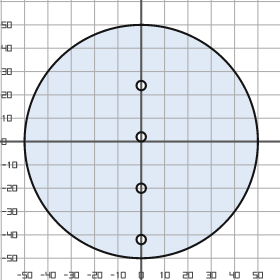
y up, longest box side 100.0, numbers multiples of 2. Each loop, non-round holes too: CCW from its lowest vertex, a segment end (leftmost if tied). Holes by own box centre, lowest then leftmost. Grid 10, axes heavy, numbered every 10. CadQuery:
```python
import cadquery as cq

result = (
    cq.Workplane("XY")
    .moveTo(0.0, 0.0)
    .circle(50.0)
    .moveTo(0.0, -42.0)
    .circle(2.0)
    .moveTo(0.0, -20.0)
    .circle(2.0)
    .moveTo(0.0, 2.0)
    .circle(2.0)
    .moveTo(0.0, 24.0)
    .circle(2.0)
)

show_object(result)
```